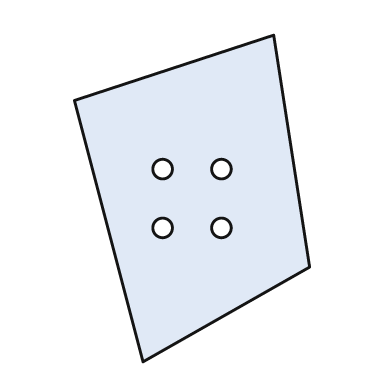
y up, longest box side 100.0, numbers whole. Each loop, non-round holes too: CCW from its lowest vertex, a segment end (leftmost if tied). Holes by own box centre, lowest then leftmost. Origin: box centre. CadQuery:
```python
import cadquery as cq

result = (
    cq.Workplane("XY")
    .moveTo(-15.0, -50.0)
    .lineTo(36.0, -21.0)
    .lineTo(25.0, 50.0)
    .lineTo(-36.0, 30.0)
    .close()
    .moveTo(-9.0, -9.0)
    .circle(3.0)
    .moveTo(9.0, -9.0)
    .circle(3.0)
    .moveTo(-9.0, 9.0)
    .circle(3.0)
    .moveTo(9.0, 9.0)
    .circle(3.0)
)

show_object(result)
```